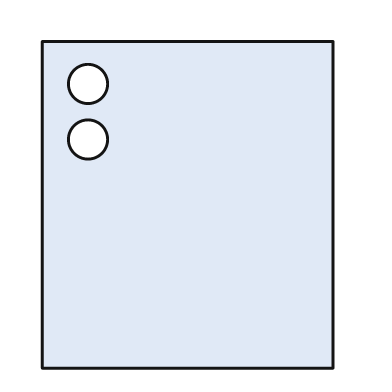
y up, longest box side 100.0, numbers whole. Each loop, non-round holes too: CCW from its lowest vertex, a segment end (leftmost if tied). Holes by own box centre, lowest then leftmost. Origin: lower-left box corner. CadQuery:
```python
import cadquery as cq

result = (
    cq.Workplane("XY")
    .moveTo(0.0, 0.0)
    .lineTo(89.0, 0.0)
    .lineTo(89.0, 100.0)
    .lineTo(0.0, 100.0)
    .close()
    .moveTo(14.0, 70.0)
    .circle(6.0)
    .moveTo(14.0, 87.0)
    .circle(6.0)
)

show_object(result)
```